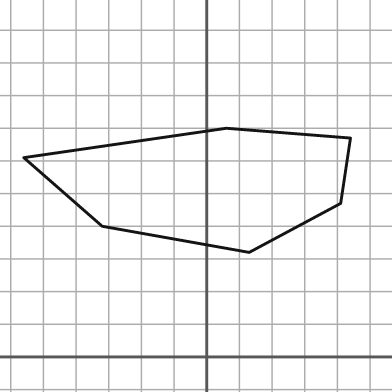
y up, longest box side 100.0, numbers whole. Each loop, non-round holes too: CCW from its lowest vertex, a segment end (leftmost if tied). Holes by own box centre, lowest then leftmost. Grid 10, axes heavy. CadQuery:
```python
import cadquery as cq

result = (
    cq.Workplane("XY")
    .moveTo(13.0, 32.0)
    .lineTo(41.0, 47.0)
    .lineTo(44.0, 67.0)
    .lineTo(6.0, 70.0)
    .lineTo(-56.0, 61.0)
    .lineTo(-32.0, 40.0)
    .close()
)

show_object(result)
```